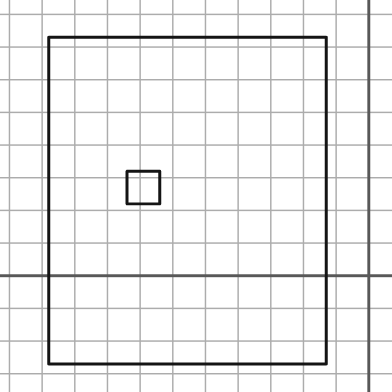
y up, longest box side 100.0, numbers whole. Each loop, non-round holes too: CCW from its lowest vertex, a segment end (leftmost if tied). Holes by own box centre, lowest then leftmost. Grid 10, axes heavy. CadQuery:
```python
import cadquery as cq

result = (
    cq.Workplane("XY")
    .moveTo(-98.0, -27.0)
    .lineTo(-13.0, -27.0)
    .lineTo(-13.0, 73.0)
    .lineTo(-98.0, 73.0)
    .close()
    .moveTo(-74.0, 22.0)
    .lineTo(-64.0, 22.0)
    .lineTo(-64.0, 32.0)
    .lineTo(-74.0, 32.0)
    .close()
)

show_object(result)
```